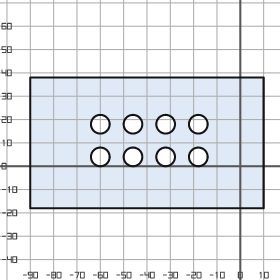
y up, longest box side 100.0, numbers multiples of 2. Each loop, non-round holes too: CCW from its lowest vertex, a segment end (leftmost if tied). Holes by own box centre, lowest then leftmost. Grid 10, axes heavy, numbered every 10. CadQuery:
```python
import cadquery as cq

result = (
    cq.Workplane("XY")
    .moveTo(-90.0, -18.0)
    .lineTo(10.0, -18.0)
    .lineTo(10.0, 38.0)
    .lineTo(-90.0, 38.0)
    .close()
    .moveTo(-60.0, 4.0)
    .circle(4.0)
    .moveTo(-46.0, 4.0)
    .circle(4.0)
    .moveTo(-32.0, 4.0)
    .circle(4.0)
    .moveTo(-18.0, 4.0)
    .circle(4.0)
    .moveTo(-60.0, 18.0)
    .circle(4.0)
    .moveTo(-46.0, 18.0)
    .circle(4.0)
    .moveTo(-32.0, 18.0)
    .circle(4.0)
    .moveTo(-18.0, 18.0)
    .circle(4.0)
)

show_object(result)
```